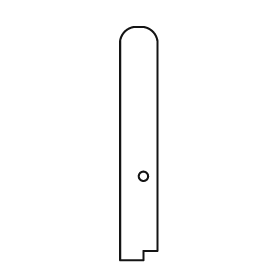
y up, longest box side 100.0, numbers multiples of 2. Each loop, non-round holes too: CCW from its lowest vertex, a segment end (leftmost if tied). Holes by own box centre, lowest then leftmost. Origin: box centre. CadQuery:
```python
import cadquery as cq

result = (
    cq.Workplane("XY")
    .moveTo(-8.0, -50.0)
    .lineTo(2.0, -50.0)
    .lineTo(2.0, -46.0)
    .lineTo(8.0, -46.0)
    .lineTo(8.0, 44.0)
    .threePointArc((6.0, 48.0), (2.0, 50.0))
    .lineTo(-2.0, 50.0)
    .threePointArc((-6.0, 48.0), (-8.0, 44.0))
    .close()
    .moveTo(2.0, -14.0)
    .circle(2.0)
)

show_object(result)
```